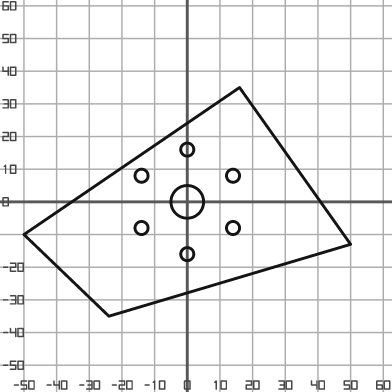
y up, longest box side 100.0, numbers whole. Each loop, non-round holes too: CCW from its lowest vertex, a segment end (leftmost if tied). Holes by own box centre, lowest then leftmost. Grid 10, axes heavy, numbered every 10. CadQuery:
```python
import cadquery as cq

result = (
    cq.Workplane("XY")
    .moveTo(-24.0, -35.0)
    .lineTo(50.0, -13.0)
    .lineTo(16.0, 35.0)
    .lineTo(-50.0, -10.0)
    .close()
    .moveTo(0.0, -16.0)
    .circle(2.0)
    .moveTo(-14.0, -8.0)
    .circle(2.0)
    .moveTo(14.0, -8.0)
    .circle(2.0)
    .moveTo(0.0, 0.0)
    .circle(5.0)
    .moveTo(-14.0, 8.0)
    .circle(2.0)
    .moveTo(14.0, 8.0)
    .circle(2.0)
    .moveTo(0.0, 16.0)
    .circle(2.0)
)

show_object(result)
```